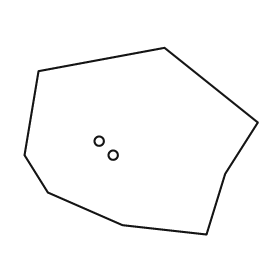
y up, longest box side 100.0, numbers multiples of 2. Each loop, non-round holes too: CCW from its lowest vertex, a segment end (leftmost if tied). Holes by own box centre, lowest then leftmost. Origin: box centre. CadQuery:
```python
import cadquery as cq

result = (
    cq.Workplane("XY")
    .moveTo(28.0, -40.0)
    .lineTo(36.0, -14.0)
    .lineTo(50.0, 8.0)
    .lineTo(10.0, 40.0)
    .lineTo(-44.0, 30.0)
    .lineTo(-50.0, -6.0)
    .lineTo(-40.0, -22.0)
    .lineTo(-8.0, -36.0)
    .close()
    .moveTo(-12.0, -6.0)
    .circle(2.0)
    .moveTo(-18.0, 0.0)
    .circle(2.0)
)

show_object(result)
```